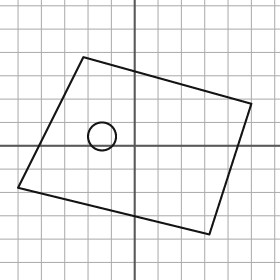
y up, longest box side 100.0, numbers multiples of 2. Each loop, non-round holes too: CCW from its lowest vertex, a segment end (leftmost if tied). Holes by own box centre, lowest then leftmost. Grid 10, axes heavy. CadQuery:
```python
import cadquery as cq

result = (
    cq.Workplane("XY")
    .moveTo(32.0, -38.0)
    .lineTo(50.0, 18.0)
    .lineTo(-22.0, 38.0)
    .lineTo(-50.0, -18.0)
    .close()
    .moveTo(-14.0, 4.0)
    .circle(6.0)
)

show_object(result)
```